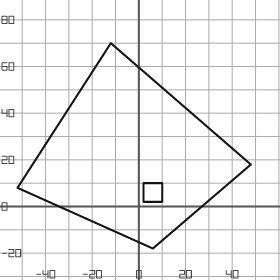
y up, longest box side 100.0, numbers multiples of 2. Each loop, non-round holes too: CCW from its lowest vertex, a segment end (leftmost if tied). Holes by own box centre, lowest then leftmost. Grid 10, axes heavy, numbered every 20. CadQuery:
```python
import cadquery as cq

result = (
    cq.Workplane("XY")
    .moveTo(6.0, -18.0)
    .lineTo(48.0, 18.0)
    .lineTo(-12.0, 70.0)
    .lineTo(-52.0, 8.0)
    .close()
    .moveTo(2.0, 2.0)
    .lineTo(10.0, 2.0)
    .lineTo(10.0, 10.0)
    .lineTo(2.0, 10.0)
    .close()
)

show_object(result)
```